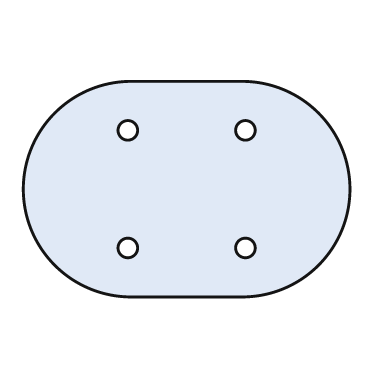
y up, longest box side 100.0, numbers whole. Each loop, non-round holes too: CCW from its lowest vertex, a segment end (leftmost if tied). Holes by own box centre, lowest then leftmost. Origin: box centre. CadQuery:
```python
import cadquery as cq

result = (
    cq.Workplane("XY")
    .moveTo(-17.0, -33.0)
    .lineTo(17.0, -33.0)
    .threePointArc((50.0, 0.0), (17.0, 33.0))
    .lineTo(-17.0, 33.0)
    .threePointArc((-50.0, 0.0), (-17.0, -33.0))
    .close()
    .moveTo(-18.0, -18.0)
    .circle(3.0)
    .moveTo(18.0, -18.0)
    .circle(3.0)
    .moveTo(-18.0, 18.0)
    .circle(3.0)
    .moveTo(18.0, 18.0)
    .circle(3.0)
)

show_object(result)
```